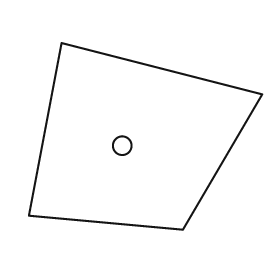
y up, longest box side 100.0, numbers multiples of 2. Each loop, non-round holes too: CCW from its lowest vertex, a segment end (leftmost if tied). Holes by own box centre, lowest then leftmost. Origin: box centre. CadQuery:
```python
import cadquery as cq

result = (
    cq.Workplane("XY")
    .moveTo(16.0, -40.0)
    .lineTo(50.0, 18.0)
    .lineTo(-36.0, 40.0)
    .lineTo(-50.0, -34.0)
    .close()
    .moveTo(-10.0, -4.0)
    .circle(4.0)
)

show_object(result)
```